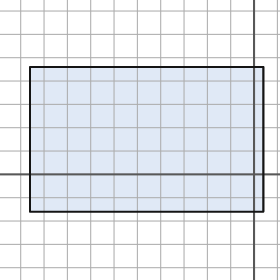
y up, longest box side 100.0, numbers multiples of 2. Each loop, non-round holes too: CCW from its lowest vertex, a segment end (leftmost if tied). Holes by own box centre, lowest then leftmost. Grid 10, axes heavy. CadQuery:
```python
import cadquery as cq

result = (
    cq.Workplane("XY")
    .moveTo(-96.0, -16.0)
    .lineTo(4.0, -16.0)
    .lineTo(4.0, 46.0)
    .lineTo(-96.0, 46.0)
    .close()
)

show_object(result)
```